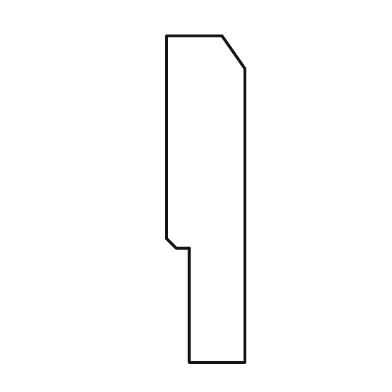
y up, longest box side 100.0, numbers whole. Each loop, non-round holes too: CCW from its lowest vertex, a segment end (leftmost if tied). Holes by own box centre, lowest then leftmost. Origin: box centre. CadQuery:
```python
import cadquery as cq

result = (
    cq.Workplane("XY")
    .moveTo(-5.0, -50.0)
    .lineTo(12.0, -50.0)
    .lineTo(12.0, 40.0)
    .lineTo(5.0, 50.0)
    .lineTo(-12.0, 50.0)
    .lineTo(-12.0, -12.0)
    .lineTo(-9.0, -15.0)
    .lineTo(-5.0, -15.0)
    .close()
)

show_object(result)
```